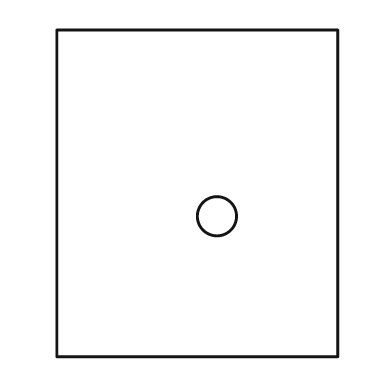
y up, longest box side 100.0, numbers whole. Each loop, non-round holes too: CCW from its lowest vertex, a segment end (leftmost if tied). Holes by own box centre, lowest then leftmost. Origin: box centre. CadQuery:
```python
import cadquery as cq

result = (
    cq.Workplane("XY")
    .moveTo(-43.0, -50.0)
    .lineTo(43.0, -50.0)
    .lineTo(43.0, 50.0)
    .lineTo(-43.0, 50.0)
    .close()
    .moveTo(6.0, -7.0)
    .circle(6.0)
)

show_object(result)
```